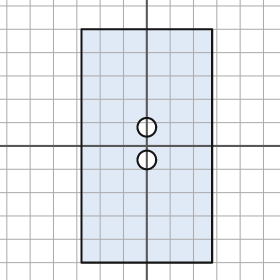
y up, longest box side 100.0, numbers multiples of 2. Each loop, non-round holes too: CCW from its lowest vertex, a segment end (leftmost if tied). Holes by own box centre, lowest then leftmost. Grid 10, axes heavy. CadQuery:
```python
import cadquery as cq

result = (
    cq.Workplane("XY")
    .moveTo(-28.0, -50.0)
    .lineTo(28.0, -50.0)
    .lineTo(28.0, 50.0)
    .lineTo(-28.0, 50.0)
    .close()
    .moveTo(0.0, -6.0)
    .circle(4.0)
    .moveTo(0.0, 8.0)
    .circle(4.0)
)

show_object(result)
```